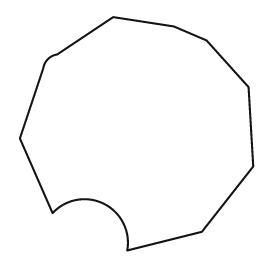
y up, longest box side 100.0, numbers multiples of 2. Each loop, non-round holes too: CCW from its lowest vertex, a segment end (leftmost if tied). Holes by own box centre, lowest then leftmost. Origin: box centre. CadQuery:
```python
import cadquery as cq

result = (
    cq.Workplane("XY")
    .moveTo(-4.0, -50.0)
    .lineTo(28.0, -42.0)
    .lineTo(50.0, -14.0)
    .lineTo(48.0, 20.0)
    .lineTo(30.0, 40.0)
    .lineTo(16.0, 46.0)
    .lineTo(-10.0, 50.0)
    .lineTo(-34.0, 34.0)
    .threePointArc((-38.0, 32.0), (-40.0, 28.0))
    .lineTo(-50.0, -2.0)
    .lineTo(-36.0, -34.0)
    .threePointArc((-14.0, -30.0), (-4.0, -50.0))
    .close()
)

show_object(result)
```